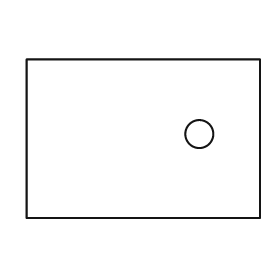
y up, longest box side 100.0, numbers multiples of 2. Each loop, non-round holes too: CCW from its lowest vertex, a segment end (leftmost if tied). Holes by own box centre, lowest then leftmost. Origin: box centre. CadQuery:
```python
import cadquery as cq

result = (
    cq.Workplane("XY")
    .moveTo(-50.0, -34.0)
    .lineTo(50.0, -34.0)
    .lineTo(50.0, 34.0)
    .lineTo(-50.0, 34.0)
    .close()
    .moveTo(24.0, 2.0)
    .circle(6.0)
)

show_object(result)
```